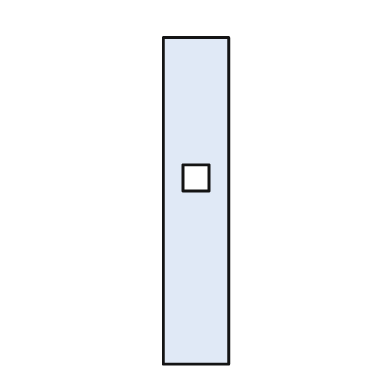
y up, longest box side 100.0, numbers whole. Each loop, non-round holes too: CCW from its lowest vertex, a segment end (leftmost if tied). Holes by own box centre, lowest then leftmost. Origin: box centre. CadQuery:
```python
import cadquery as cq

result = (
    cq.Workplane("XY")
    .moveTo(-10.0, -50.0)
    .lineTo(10.0, -50.0)
    .lineTo(10.0, 50.0)
    .lineTo(-10.0, 50.0)
    .close()
    .moveTo(-4.0, 3.0)
    .lineTo(4.0, 3.0)
    .lineTo(4.0, 11.0)
    .lineTo(-4.0, 11.0)
    .close()
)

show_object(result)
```